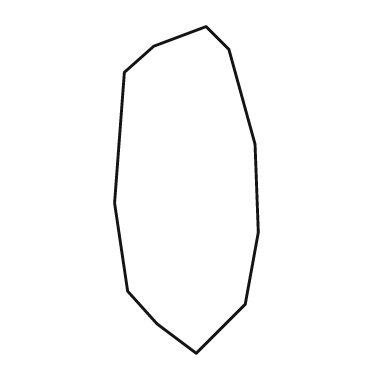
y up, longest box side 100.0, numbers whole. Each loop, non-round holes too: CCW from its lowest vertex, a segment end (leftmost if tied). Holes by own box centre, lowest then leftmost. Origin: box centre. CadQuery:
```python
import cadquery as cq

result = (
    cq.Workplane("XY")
    .moveTo(3.0, -50.0)
    .lineTo(18.0, -35.0)
    .lineTo(22.0, -13.0)
    .lineTo(21.0, 14.0)
    .lineTo(13.0, 43.0)
    .lineTo(6.0, 50.0)
    .lineTo(-10.0, 44.0)
    .lineTo(-19.0, 36.0)
    .lineTo(-22.0, -4.0)
    .lineTo(-18.0, -31.0)
    .lineTo(-9.0, -41.0)
    .close()
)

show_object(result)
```